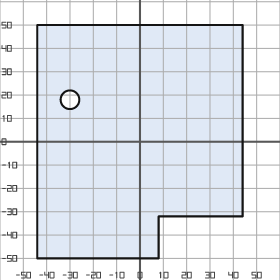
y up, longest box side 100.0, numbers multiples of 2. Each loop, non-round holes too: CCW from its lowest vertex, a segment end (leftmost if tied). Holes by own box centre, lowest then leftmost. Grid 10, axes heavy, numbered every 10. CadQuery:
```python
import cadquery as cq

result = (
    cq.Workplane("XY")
    .moveTo(-44.0, -50.0)
    .lineTo(8.0, -50.0)
    .lineTo(8.0, -32.0)
    .lineTo(44.0, -32.0)
    .lineTo(44.0, 50.0)
    .lineTo(-44.0, 50.0)
    .close()
    .moveTo(-30.0, 18.0)
    .circle(4.0)
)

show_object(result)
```